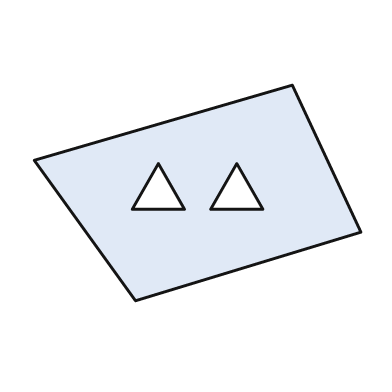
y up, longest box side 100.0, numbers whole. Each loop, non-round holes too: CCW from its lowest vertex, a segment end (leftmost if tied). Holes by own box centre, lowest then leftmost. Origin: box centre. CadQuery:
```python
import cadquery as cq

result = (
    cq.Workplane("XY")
    .moveTo(-19.0, -33.0)
    .lineTo(50.0, -12.0)
    .lineTo(29.0, 33.0)
    .lineTo(-50.0, 10.0)
    .close()
    .moveTo(-20.0, -5.0)
    .lineTo(-4.0, -5.0)
    .lineTo(-12.0, 9.0)
    .close()
    .moveTo(4.0, -5.0)
    .lineTo(20.0, -5.0)
    .lineTo(12.0, 9.0)
    .close()
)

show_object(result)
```